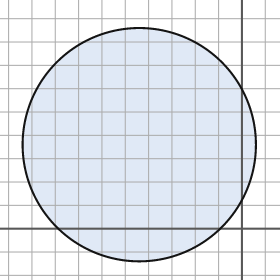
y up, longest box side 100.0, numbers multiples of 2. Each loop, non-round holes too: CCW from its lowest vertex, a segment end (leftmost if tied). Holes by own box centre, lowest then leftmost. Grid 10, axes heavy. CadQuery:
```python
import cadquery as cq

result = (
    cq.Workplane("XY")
    .moveTo(-44.0, 36.0)
    .circle(50.0)
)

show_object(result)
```